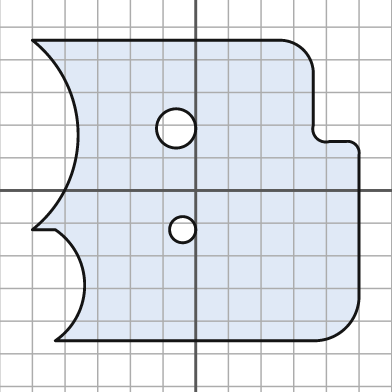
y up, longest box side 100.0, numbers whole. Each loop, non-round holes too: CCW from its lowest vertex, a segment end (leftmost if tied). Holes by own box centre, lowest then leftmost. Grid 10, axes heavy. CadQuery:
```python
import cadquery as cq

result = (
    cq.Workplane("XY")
    .moveTo(-43.0, -46.0)
    .lineTo(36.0, -46.0)
    .threePointArc((46.0, -42.0), (50.0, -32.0))
    .lineTo(50.0, 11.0)
    .threePointArc((49.0, 14.0), (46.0, 15.0))
    .lineTo(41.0, 15.0)
    .threePointArc((37.0, 16.0), (36.0, 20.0))
    .lineTo(36.0, 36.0)
    .threePointArc((33.0, 43.0), (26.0, 46.0))
    .lineTo(-50.0, 46.0)
    .threePointArc((-36.0, 17.0), (-50.0, -12.0))
    .lineTo(-43.0, -12.0)
    .threePointArc((-34.0, -29.0), (-43.0, -46.0))
    .close()
    .moveTo(-4.0, -12.0)
    .circle(4.0)
    .moveTo(-6.0, 19.0)
    .circle(6.0)
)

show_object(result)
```